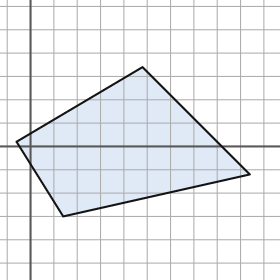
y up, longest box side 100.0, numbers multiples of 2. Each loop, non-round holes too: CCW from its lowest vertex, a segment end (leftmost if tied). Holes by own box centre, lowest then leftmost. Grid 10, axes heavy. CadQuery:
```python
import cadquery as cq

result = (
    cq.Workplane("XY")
    .moveTo(14.0, -30.0)
    .lineTo(94.0, -12.0)
    .lineTo(48.0, 34.0)
    .lineTo(-6.0, 2.0)
    .close()
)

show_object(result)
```